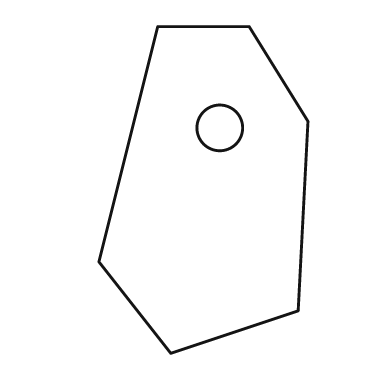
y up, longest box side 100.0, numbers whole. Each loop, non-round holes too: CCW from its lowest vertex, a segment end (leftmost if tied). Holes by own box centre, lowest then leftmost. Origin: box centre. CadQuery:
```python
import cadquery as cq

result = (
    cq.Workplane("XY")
    .moveTo(-10.0, -50.0)
    .lineTo(29.0, -37.0)
    .lineTo(32.0, 21.0)
    .lineTo(14.0, 50.0)
    .lineTo(-14.0, 50.0)
    .lineTo(-32.0, -22.0)
    .close()
    .moveTo(5.0, 19.0)
    .circle(7.0)
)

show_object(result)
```